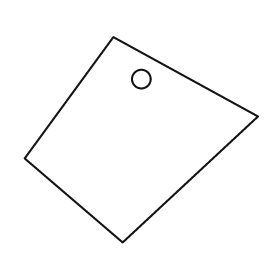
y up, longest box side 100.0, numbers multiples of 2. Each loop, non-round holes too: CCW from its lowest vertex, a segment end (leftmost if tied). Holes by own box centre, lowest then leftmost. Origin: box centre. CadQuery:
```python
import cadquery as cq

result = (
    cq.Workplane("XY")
    .moveTo(-8.0, -44.0)
    .lineTo(50.0, 10.0)
    .lineTo(-12.0, 44.0)
    .lineTo(-50.0, -8.0)
    .close()
    .moveTo(0.0, 26.0)
    .circle(4.0)
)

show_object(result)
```